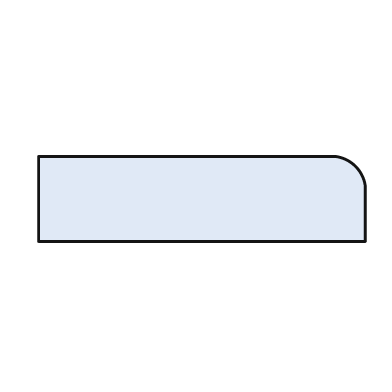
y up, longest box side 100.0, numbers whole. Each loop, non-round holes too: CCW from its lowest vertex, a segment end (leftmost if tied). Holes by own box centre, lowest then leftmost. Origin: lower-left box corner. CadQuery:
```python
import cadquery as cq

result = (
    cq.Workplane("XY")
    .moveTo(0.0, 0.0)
    .lineTo(100.0, 0.0)
    .lineTo(100.0, 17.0)
    .threePointArc((97.0, 23.0), (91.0, 26.0))
    .lineTo(0.0, 26.0)
    .close()
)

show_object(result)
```